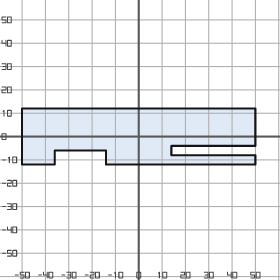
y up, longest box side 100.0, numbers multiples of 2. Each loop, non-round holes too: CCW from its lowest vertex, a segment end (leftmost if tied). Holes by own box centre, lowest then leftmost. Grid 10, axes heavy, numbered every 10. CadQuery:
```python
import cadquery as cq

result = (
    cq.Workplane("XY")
    .moveTo(-50.0, -12.0)
    .lineTo(-36.0, -12.0)
    .lineTo(-36.0, -6.0)
    .lineTo(-14.0, -6.0)
    .lineTo(-14.0, -12.0)
    .lineTo(50.0, -12.0)
    .lineTo(50.0, -8.0)
    .lineTo(14.0, -8.0)
    .lineTo(14.0, -4.0)
    .lineTo(50.0, -4.0)
    .lineTo(50.0, 12.0)
    .lineTo(-50.0, 12.0)
    .close()
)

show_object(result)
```